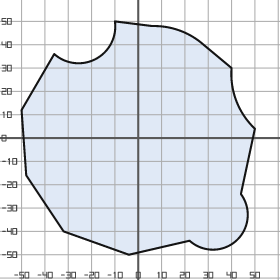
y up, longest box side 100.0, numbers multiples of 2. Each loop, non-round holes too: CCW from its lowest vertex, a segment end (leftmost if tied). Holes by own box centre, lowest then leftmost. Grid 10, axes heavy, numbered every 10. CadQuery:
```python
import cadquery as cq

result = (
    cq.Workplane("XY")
    .moveTo(-4.0, -50.0)
    .lineTo(22.0, -44.0)
    .threePointArc((42.0, -44.0), (44.0, -24.0))
    .lineTo(50.0, 4.0)
    .threePointArc((42.0, 16.0), (40.0, 30.0))
    .lineTo(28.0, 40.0)
    .threePointArc((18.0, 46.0), (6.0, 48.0))
    .lineTo(-10.0, 50.0)
    .threePointArc((-18.0, 34.0), (-36.0, 36.0))
    .lineTo(-50.0, 12.0)
    .lineTo(-48.0, -16.0)
    .lineTo(-32.0, -40.0)
    .close()
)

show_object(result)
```